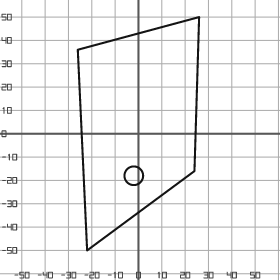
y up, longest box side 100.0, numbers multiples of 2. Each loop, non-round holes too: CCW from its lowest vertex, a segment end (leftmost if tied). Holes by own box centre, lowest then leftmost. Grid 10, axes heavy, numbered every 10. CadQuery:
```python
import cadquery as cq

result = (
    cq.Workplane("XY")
    .moveTo(-22.0, -50.0)
    .lineTo(24.0, -16.0)
    .lineTo(26.0, 50.0)
    .lineTo(-26.0, 36.0)
    .close()
    .moveTo(-2.0, -18.0)
    .circle(4.0)
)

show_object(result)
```